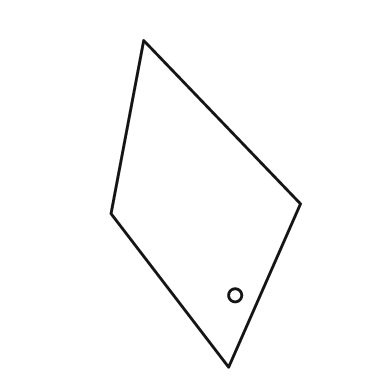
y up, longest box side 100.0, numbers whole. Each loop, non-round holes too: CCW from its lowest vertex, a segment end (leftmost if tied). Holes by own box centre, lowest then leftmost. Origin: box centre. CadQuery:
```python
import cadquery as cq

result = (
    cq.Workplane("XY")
    .moveTo(7.0, -50.0)
    .lineTo(29.0, 0.0)
    .lineTo(-19.0, 50.0)
    .lineTo(-29.0, -3.0)
    .close()
    .moveTo(9.0, -28.0)
    .circle(2.0)
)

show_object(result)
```